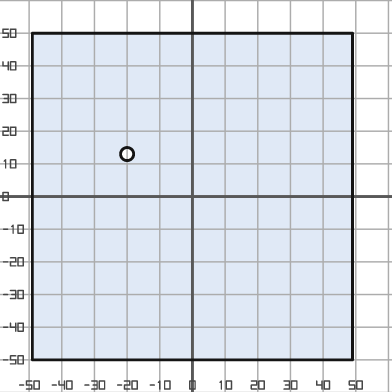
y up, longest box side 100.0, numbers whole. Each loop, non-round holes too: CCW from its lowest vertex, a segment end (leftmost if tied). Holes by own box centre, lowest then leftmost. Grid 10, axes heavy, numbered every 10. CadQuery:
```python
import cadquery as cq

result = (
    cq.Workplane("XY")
    .moveTo(-49.0, -50.0)
    .lineTo(49.0, -50.0)
    .lineTo(49.0, 50.0)
    .lineTo(-49.0, 50.0)
    .close()
    .moveTo(-20.0, 13.0)
    .circle(2.0)
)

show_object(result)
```